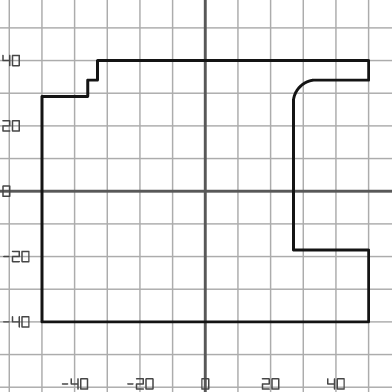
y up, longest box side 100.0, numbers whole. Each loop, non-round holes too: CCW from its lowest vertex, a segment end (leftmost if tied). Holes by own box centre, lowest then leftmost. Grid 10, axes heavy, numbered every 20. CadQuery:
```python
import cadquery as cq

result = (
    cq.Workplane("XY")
    .moveTo(-50.0, -40.0)
    .lineTo(50.0, -40.0)
    .lineTo(50.0, -18.0)
    .lineTo(27.0, -18.0)
    .lineTo(27.0, 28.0)
    .threePointArc((29.0, 32.0), (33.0, 34.0))
    .lineTo(50.0, 34.0)
    .lineTo(50.0, 40.0)
    .lineTo(-33.0, 40.0)
    .lineTo(-33.0, 34.0)
    .lineTo(-36.0, 34.0)
    .lineTo(-36.0, 29.0)
    .lineTo(-50.0, 29.0)
    .close()
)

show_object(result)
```